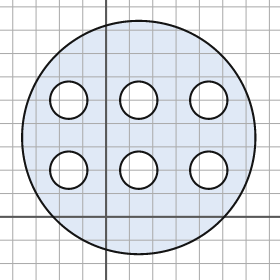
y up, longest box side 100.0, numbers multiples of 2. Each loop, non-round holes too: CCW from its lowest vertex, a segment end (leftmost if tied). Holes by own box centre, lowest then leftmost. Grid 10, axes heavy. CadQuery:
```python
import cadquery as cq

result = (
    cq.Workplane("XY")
    .moveTo(14.0, 34.0)
    .circle(50.0)
    .moveTo(-16.0, 20.0)
    .circle(8.0)
    .moveTo(14.0, 20.0)
    .circle(8.0)
    .moveTo(44.0, 20.0)
    .circle(8.0)
    .moveTo(-16.0, 50.0)
    .circle(8.0)
    .moveTo(14.0, 50.0)
    .circle(8.0)
    .moveTo(44.0, 50.0)
    .circle(8.0)
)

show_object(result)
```